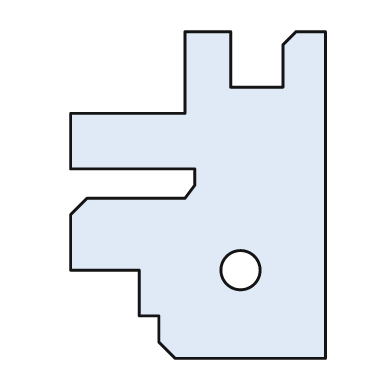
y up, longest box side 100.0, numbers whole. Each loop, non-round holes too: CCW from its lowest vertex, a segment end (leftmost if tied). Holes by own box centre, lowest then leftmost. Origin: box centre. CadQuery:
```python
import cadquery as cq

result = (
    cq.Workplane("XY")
    .moveTo(-7.0, -50.0)
    .lineTo(39.0, -50.0)
    .lineTo(39.0, 50.0)
    .lineTo(30.0, 50.0)
    .lineTo(26.0, 46.0)
    .lineTo(26.0, 33.0)
    .lineTo(10.0, 33.0)
    .lineTo(10.0, 50.0)
    .lineTo(-4.0, 50.0)
    .lineTo(-4.0, 25.0)
    .lineTo(-39.0, 25.0)
    .lineTo(-39.0, 8.0)
    .lineTo(-1.0, 8.0)
    .lineTo(-1.0, 3.0)
    .lineTo(-4.0, -1.0)
    .lineTo(-34.0, -1.0)
    .lineTo(-39.0, -6.0)
    .lineTo(-39.0, -23.0)
    .lineTo(-18.0, -23.0)
    .lineTo(-18.0, -37.0)
    .lineTo(-12.0, -37.0)
    .lineTo(-12.0, -45.0)
    .close()
    .moveTo(13.0, -23.0)
    .circle(6.0)
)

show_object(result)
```